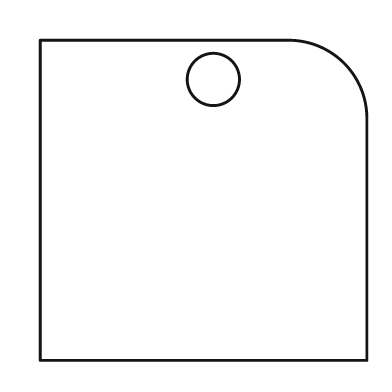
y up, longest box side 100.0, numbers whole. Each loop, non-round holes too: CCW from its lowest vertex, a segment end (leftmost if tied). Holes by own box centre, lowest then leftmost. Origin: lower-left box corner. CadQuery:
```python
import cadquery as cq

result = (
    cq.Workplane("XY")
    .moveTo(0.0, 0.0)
    .lineTo(100.0, 0.0)
    .lineTo(100.0, 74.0)
    .threePointArc((93.0, 91.0), (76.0, 98.0))
    .lineTo(0.0, 98.0)
    .close()
    .moveTo(53.0, 86.0)
    .circle(8.0)
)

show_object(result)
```